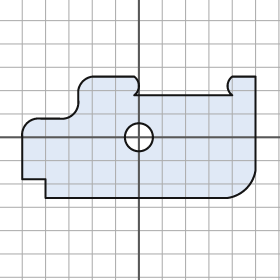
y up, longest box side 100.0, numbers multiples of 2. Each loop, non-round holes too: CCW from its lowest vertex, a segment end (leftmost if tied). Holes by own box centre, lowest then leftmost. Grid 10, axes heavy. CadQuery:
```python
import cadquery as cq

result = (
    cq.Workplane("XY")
    .moveTo(-40.0, -26.0)
    .lineTo(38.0, -26.0)
    .threePointArc((46.0, -22.0), (50.0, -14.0))
    .lineTo(50.0, 26.0)
    .lineTo(40.0, 26.0)
    .threePointArc((38.0, 22.0), (40.0, 18.0))
    .lineTo(-2.0, 18.0)
    .threePointArc((0.0, 22.0), (-2.0, 26.0))
    .lineTo(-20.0, 26.0)
    .threePointArc((-24.0, 24.0), (-26.0, 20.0))
    .lineTo(-26.0, 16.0)
    .threePointArc((-28.0, 10.0), (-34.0, 8.0))
    .lineTo(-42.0, 8.0)
    .threePointArc((-48.0, 6.0), (-50.0, 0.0))
    .lineTo(-50.0, -18.0)
    .lineTo(-40.0, -18.0)
    .close()
    .moveTo(0.0, 0.0)
    .circle(6.0)
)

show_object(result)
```